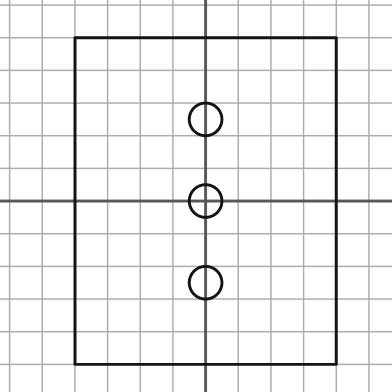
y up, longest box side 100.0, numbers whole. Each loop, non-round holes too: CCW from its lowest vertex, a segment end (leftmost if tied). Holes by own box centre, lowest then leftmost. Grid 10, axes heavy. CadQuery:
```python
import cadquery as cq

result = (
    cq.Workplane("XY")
    .moveTo(-40.0, -50.0)
    .lineTo(40.0, -50.0)
    .lineTo(40.0, 50.0)
    .lineTo(-40.0, 50.0)
    .close()
    .moveTo(0.0, -25.0)
    .circle(5.0)
    .moveTo(0.0, 0.0)
    .circle(5.0)
    .moveTo(0.0, 25.0)
    .circle(5.0)
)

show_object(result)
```